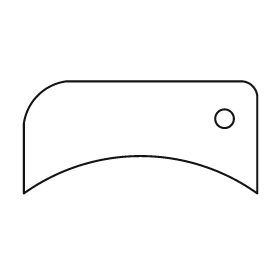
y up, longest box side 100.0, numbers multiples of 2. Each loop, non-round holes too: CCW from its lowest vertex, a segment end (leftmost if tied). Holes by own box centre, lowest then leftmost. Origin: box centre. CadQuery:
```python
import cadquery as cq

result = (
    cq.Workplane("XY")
    .moveTo(-50.0, -24.0)
    .threePointArc((0.0, -8.0), (50.0, -24.0))
    .lineTo(50.0, 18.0)
    .threePointArc((48.0, 22.0), (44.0, 24.0))
    .lineTo(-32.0, 24.0)
    .threePointArc((-44.0, 18.0), (-50.0, 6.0))
    .close()
    .moveTo(36.0, 8.0)
    .circle(4.0)
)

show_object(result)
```